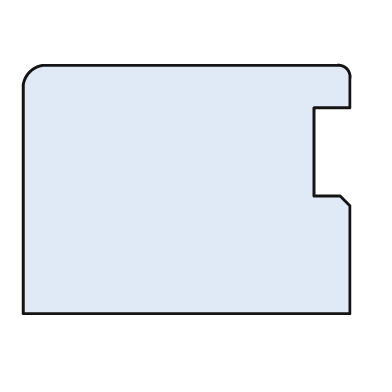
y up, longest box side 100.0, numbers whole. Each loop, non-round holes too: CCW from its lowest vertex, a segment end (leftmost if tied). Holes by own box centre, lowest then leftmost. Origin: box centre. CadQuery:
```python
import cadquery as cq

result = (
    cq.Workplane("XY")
    .moveTo(-50.0, -38.0)
    .lineTo(50.0, -38.0)
    .lineTo(50.0, -5.0)
    .lineTo(47.0, -2.0)
    .lineTo(39.0, -2.0)
    .lineTo(39.0, 25.0)
    .lineTo(50.0, 25.0)
    .lineTo(50.0, 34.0)
    .threePointArc((49.0, 37.0), (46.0, 38.0))
    .lineTo(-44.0, 38.0)
    .threePointArc((-48.0, 36.0), (-50.0, 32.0))
    .close()
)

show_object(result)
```